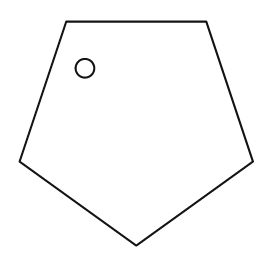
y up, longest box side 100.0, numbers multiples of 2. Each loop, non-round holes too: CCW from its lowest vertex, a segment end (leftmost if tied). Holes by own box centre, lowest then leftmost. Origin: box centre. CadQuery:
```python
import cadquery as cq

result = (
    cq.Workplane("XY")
    .moveTo(0.0, -48.0)
    .lineTo(50.0, -12.0)
    .lineTo(30.0, 48.0)
    .lineTo(-30.0, 48.0)
    .lineTo(-50.0, -12.0)
    .close()
    .moveTo(-22.0, 28.0)
    .circle(4.0)
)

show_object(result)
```